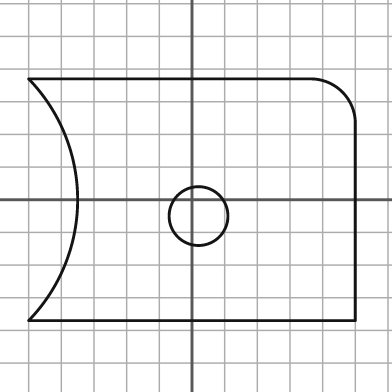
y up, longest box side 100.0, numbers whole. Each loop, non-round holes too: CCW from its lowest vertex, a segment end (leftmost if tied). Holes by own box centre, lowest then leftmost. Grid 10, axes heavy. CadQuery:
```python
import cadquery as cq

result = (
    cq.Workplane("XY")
    .moveTo(-50.0, -37.0)
    .lineTo(50.0, -37.0)
    .lineTo(50.0, 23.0)
    .threePointArc((46.0, 33.0), (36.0, 37.0))
    .lineTo(-50.0, 37.0)
    .threePointArc((-35.0, 0.0), (-50.0, -37.0))
    .close()
    .moveTo(2.0, -5.0)
    .circle(9.0)
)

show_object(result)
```